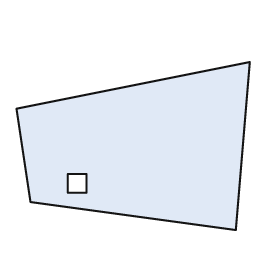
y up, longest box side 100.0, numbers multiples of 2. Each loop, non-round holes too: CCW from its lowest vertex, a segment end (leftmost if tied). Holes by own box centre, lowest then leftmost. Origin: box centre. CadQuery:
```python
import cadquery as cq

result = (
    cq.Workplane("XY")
    .moveTo(44.0, -36.0)
    .lineTo(50.0, 36.0)
    .lineTo(-50.0, 16.0)
    .lineTo(-44.0, -24.0)
    .close()
    .moveTo(-28.0, -20.0)
    .lineTo(-20.0, -20.0)
    .lineTo(-20.0, -12.0)
    .lineTo(-28.0, -12.0)
    .close()
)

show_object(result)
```